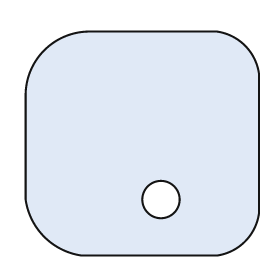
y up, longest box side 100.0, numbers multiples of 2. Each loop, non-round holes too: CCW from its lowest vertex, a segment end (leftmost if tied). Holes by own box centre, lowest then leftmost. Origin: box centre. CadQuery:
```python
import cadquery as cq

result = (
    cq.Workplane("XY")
    .moveTo(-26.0, -48.0)
    .lineTo(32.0, -48.0)
    .threePointArc((44.0, -42.0), (50.0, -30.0))
    .lineTo(50.0, 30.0)
    .threePointArc((44.0, 42.0), (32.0, 48.0))
    .lineTo(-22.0, 48.0)
    .threePointArc((-42.0, 40.0), (-50.0, 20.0))
    .lineTo(-50.0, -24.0)
    .threePointArc((-42.0, -40.0), (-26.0, -48.0))
    .close()
    .moveTo(8.0, -24.0)
    .circle(8.0)
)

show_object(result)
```